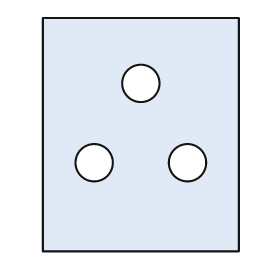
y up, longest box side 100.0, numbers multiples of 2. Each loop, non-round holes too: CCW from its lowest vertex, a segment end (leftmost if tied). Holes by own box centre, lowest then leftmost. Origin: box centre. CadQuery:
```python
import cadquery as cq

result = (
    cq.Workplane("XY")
    .moveTo(-42.0, -50.0)
    .lineTo(42.0, -50.0)
    .lineTo(42.0, 50.0)
    .lineTo(-42.0, 50.0)
    .close()
    .moveTo(-20.0, -12.0)
    .circle(8.0)
    .moveTo(20.0, -12.0)
    .circle(8.0)
    .moveTo(0.0, 22.0)
    .circle(8.0)
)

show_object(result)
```